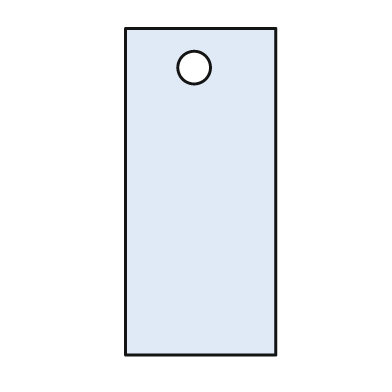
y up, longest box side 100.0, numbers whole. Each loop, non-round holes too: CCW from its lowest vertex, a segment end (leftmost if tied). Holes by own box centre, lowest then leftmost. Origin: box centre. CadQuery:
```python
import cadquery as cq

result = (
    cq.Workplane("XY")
    .moveTo(-23.0, -50.0)
    .lineTo(23.0, -50.0)
    .lineTo(23.0, 50.0)
    .lineTo(-23.0, 50.0)
    .close()
    .moveTo(-2.0, 38.0)
    .circle(5.0)
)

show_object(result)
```